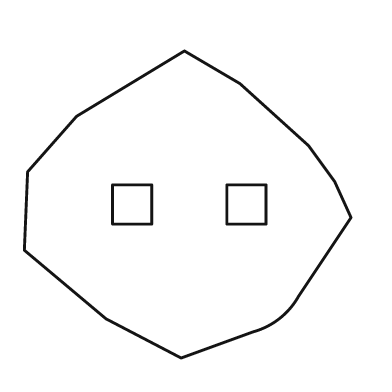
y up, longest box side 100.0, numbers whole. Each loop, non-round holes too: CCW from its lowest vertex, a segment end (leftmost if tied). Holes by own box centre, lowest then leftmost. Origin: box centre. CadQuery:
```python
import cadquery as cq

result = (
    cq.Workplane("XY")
    .moveTo(-2.0, -47.0)
    .lineTo(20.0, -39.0)
    .threePointArc((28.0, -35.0), (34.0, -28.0))
    .lineTo(50.0, -4.0)
    .lineTo(45.0, 7.0)
    .lineTo(37.0, 18.0)
    .lineTo(16.0, 37.0)
    .lineTo(-1.0, 47.0)
    .lineTo(-34.0, 27.0)
    .lineTo(-49.0, 10.0)
    .lineTo(-50.0, -14.0)
    .lineTo(-25.0, -35.0)
    .close()
    .moveTo(-23.0, -6.0)
    .lineTo(-11.0, -6.0)
    .lineTo(-11.0, 6.0)
    .lineTo(-23.0, 6.0)
    .close()
    .moveTo(12.0, -6.0)
    .lineTo(24.0, -6.0)
    .lineTo(24.0, 6.0)
    .lineTo(12.0, 6.0)
    .close()
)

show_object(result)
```